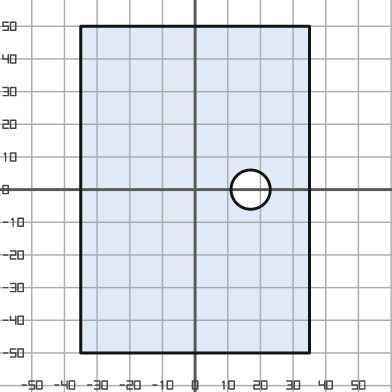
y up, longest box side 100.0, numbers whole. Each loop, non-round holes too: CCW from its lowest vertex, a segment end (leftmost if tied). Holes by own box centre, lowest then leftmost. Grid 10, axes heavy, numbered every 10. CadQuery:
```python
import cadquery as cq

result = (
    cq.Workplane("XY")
    .moveTo(-35.0, -50.0)
    .lineTo(35.0, -50.0)
    .lineTo(35.0, 50.0)
    .lineTo(-35.0, 50.0)
    .close()
    .moveTo(17.0, 0.0)
    .circle(6.0)
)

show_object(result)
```